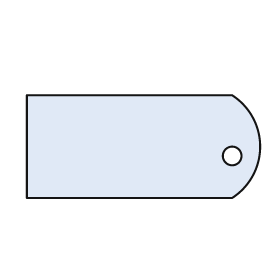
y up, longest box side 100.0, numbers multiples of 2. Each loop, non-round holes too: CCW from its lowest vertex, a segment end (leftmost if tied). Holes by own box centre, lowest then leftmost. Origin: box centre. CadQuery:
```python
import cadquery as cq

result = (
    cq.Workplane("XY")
    .moveTo(-50.0, -22.0)
    .lineTo(38.0, -22.0)
    .threePointArc((50.0, 0.0), (38.0, 22.0))
    .lineTo(-50.0, 22.0)
    .close()
    .moveTo(38.0, -4.0)
    .circle(4.0)
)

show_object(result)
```